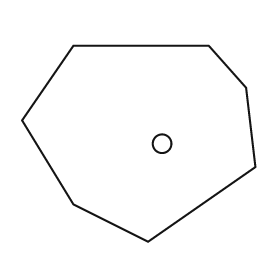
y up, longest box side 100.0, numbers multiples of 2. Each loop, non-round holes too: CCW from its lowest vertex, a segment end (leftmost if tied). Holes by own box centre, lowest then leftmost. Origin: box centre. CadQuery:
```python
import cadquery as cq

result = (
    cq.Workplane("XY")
    .moveTo(4.0, -42.0)
    .lineTo(50.0, -10.0)
    .lineTo(46.0, 24.0)
    .lineTo(30.0, 42.0)
    .lineTo(-28.0, 42.0)
    .lineTo(-50.0, 10.0)
    .lineTo(-28.0, -26.0)
    .close()
    .moveTo(10.0, 0.0)
    .circle(4.0)
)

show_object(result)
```